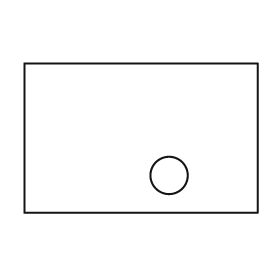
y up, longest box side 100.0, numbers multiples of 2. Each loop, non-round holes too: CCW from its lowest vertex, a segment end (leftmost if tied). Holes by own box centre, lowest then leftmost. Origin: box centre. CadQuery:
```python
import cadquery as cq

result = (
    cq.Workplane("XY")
    .moveTo(-50.0, -32.0)
    .lineTo(50.0, -32.0)
    .lineTo(50.0, 32.0)
    .lineTo(-50.0, 32.0)
    .close()
    .moveTo(12.0, -16.0)
    .circle(8.0)
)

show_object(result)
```